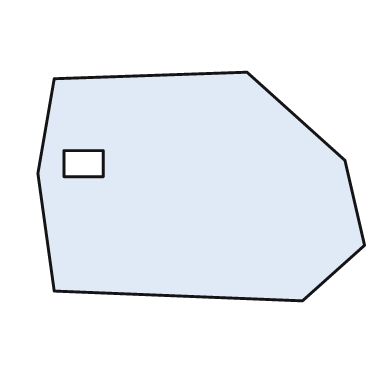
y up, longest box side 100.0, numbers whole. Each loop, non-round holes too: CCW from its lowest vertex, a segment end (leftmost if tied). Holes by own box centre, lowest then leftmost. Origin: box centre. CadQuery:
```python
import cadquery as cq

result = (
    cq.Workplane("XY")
    .moveTo(31.0, -35.0)
    .lineTo(50.0, -18.0)
    .lineTo(44.0, 8.0)
    .lineTo(14.0, 35.0)
    .lineTo(-45.0, 33.0)
    .lineTo(-50.0, 4.0)
    .lineTo(-45.0, -32.0)
    .close()
    .moveTo(-42.0, 3.0)
    .lineTo(-30.0, 3.0)
    .lineTo(-30.0, 11.0)
    .lineTo(-42.0, 11.0)
    .close()
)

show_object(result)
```